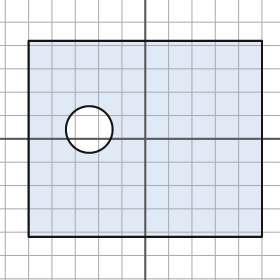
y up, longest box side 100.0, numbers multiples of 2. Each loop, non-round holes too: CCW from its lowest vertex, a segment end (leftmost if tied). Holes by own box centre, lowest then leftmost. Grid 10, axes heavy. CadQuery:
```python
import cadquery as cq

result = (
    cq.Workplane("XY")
    .moveTo(-50.0, -42.0)
    .lineTo(50.0, -42.0)
    .lineTo(50.0, 42.0)
    .lineTo(-50.0, 42.0)
    .close()
    .moveTo(-24.0, 4.0)
    .circle(10.0)
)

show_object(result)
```